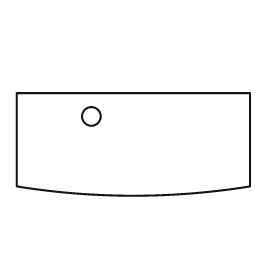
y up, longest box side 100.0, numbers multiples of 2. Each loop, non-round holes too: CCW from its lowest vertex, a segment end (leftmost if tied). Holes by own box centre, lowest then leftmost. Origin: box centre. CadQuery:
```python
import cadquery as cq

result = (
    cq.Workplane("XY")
    .moveTo(-50.0, -18.0)
    .threePointArc((0.0, -22.0), (50.0, -18.0))
    .lineTo(50.0, 22.0)
    .lineTo(-50.0, 22.0)
    .close()
    .moveTo(-18.0, 12.0)
    .circle(4.0)
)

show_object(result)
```